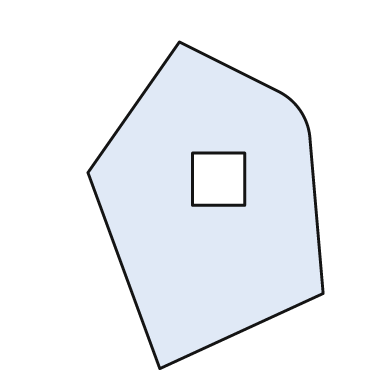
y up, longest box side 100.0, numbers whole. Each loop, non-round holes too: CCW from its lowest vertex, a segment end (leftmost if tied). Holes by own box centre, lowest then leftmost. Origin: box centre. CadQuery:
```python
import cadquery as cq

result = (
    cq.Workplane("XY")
    .moveTo(-14.0, -50.0)
    .lineTo(36.0, -27.0)
    .lineTo(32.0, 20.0)
    .threePointArc((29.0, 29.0), (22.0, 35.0))
    .lineTo(-8.0, 50.0)
    .lineTo(-36.0, 10.0)
    .close()
    .moveTo(-4.0, 0.0)
    .lineTo(12.0, 0.0)
    .lineTo(12.0, 16.0)
    .lineTo(-4.0, 16.0)
    .close()
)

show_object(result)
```